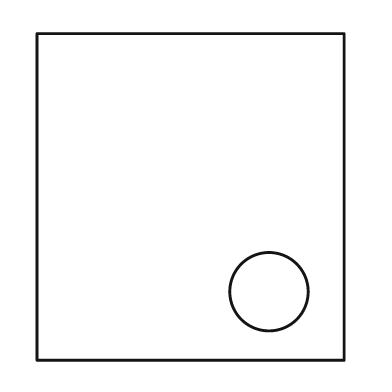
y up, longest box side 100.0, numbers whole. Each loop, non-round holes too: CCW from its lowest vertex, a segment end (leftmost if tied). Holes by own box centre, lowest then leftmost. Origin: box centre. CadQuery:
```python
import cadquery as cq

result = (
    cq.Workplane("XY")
    .moveTo(-47.0, -50.0)
    .lineTo(47.0, -50.0)
    .lineTo(47.0, 50.0)
    .lineTo(-47.0, 50.0)
    .close()
    .moveTo(24.0, -29.0)
    .circle(12.0)
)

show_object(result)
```